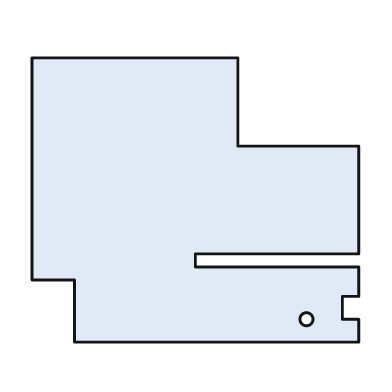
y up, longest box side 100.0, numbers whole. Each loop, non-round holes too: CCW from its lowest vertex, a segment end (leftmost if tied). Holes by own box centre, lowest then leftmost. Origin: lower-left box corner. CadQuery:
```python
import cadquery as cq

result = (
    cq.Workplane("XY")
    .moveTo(13.0, 0.0)
    .lineTo(100.0, 0.0)
    .lineTo(100.0, 7.0)
    .lineTo(95.0, 7.0)
    .lineTo(95.0, 14.0)
    .lineTo(100.0, 14.0)
    .lineTo(100.0, 23.0)
    .lineTo(50.0, 23.0)
    .lineTo(50.0, 27.0)
    .lineTo(100.0, 27.0)
    .lineTo(100.0, 60.0)
    .lineTo(63.0, 60.0)
    .lineTo(63.0, 87.0)
    .lineTo(0.0, 87.0)
    .lineTo(0.0, 19.0)
    .lineTo(13.0, 19.0)
    .close()
    .moveTo(84.0, 7.0)
    .circle(2.0)
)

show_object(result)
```